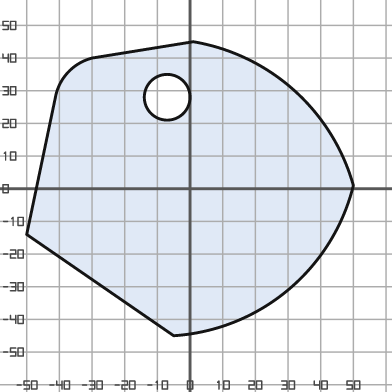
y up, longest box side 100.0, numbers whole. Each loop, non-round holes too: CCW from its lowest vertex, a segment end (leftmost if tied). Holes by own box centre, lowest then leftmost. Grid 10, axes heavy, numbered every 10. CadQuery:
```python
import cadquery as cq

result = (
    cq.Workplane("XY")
    .moveTo(-5.0, -45.0)
    .threePointArc((30.0, -31.0), (50.0, 1.0))
    .threePointArc((32.0, 30.0), (1.0, 45.0))
    .lineTo(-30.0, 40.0)
    .threePointArc((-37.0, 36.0), (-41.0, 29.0))
    .lineTo(-50.0, -14.0)
    .close()
    .moveTo(-7.0, 28.0)
    .circle(7.0)
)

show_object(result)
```